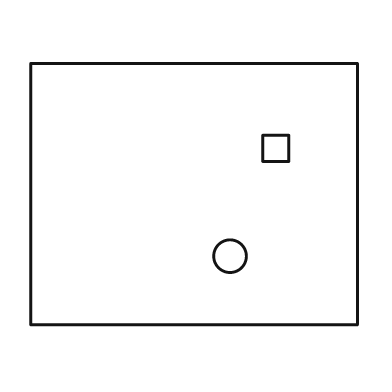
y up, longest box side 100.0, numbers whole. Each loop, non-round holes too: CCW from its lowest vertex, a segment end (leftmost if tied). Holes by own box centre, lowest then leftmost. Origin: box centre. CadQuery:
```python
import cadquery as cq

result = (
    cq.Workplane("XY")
    .moveTo(-50.0, -40.0)
    .lineTo(50.0, -40.0)
    .lineTo(50.0, 40.0)
    .lineTo(-50.0, 40.0)
    .close()
    .moveTo(11.0, -19.0)
    .circle(5.0)
    .moveTo(21.0, 10.0)
    .lineTo(29.0, 10.0)
    .lineTo(29.0, 18.0)
    .lineTo(21.0, 18.0)
    .close()
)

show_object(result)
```